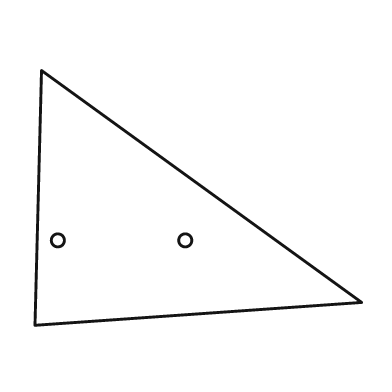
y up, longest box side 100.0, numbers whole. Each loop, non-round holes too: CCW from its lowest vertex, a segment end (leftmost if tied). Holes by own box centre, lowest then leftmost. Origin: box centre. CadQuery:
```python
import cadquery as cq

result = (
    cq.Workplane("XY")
    .moveTo(-50.0, -39.0)
    .lineTo(50.0, -32.0)
    .lineTo(-48.0, 39.0)
    .close()
    .moveTo(-43.0, -13.0)
    .circle(2.0)
    .moveTo(-4.0, -13.0)
    .circle(2.0)
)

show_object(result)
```